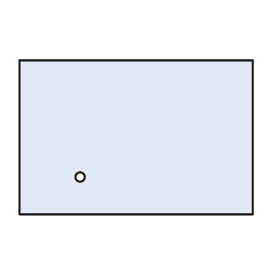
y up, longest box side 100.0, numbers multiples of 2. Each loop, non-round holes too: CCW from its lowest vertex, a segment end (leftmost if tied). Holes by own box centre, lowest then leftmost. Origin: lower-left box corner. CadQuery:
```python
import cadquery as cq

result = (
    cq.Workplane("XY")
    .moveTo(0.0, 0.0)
    .lineTo(100.0, 0.0)
    .lineTo(100.0, 66.0)
    .lineTo(0.0, 66.0)
    .close()
    .moveTo(26.0, 16.0)
    .circle(2.0)
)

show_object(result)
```